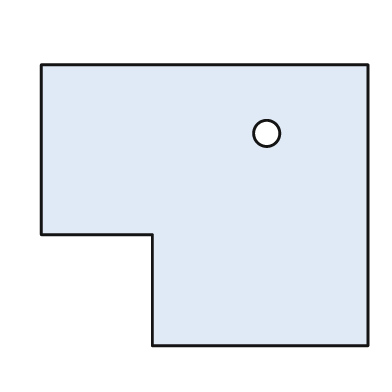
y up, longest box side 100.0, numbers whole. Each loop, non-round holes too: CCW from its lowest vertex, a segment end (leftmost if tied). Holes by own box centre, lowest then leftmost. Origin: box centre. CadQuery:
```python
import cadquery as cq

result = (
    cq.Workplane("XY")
    .moveTo(-16.0, -43.0)
    .lineTo(50.0, -43.0)
    .lineTo(50.0, 43.0)
    .lineTo(-50.0, 43.0)
    .lineTo(-50.0, -9.0)
    .lineTo(-16.0, -9.0)
    .close()
    .moveTo(19.0, 22.0)
    .circle(4.0)
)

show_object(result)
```